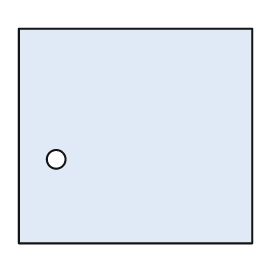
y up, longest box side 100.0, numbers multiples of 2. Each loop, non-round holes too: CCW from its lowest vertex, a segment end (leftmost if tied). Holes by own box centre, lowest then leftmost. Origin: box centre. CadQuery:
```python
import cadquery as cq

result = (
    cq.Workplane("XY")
    .moveTo(-50.0, -46.0)
    .lineTo(50.0, -46.0)
    .lineTo(50.0, 46.0)
    .lineTo(-50.0, 46.0)
    .close()
    .moveTo(-34.0, -10.0)
    .circle(4.0)
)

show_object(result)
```